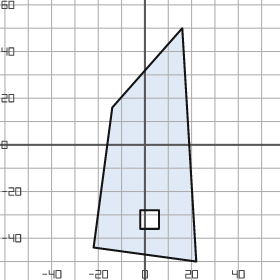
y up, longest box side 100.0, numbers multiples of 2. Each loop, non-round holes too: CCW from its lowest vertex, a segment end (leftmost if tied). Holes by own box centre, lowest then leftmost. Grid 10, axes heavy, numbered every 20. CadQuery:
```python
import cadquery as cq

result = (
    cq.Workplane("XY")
    .moveTo(22.0, -50.0)
    .lineTo(16.0, 50.0)
    .lineTo(-14.0, 16.0)
    .lineTo(-22.0, -44.0)
    .close()
    .moveTo(-2.0, -36.0)
    .lineTo(6.0, -36.0)
    .lineTo(6.0, -28.0)
    .lineTo(-2.0, -28.0)
    .close()
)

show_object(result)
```